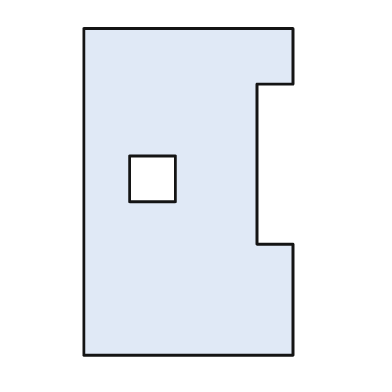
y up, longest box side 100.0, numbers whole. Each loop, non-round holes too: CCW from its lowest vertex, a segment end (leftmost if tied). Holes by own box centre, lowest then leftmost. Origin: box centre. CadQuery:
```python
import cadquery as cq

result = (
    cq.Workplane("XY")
    .moveTo(-32.0, -50.0)
    .lineTo(32.0, -50.0)
    .lineTo(32.0, -16.0)
    .lineTo(21.0, -16.0)
    .lineTo(21.0, 33.0)
    .lineTo(32.0, 33.0)
    .lineTo(32.0, 50.0)
    .lineTo(-32.0, 50.0)
    .close()
    .moveTo(-18.0, -3.0)
    .lineTo(-4.0, -3.0)
    .lineTo(-4.0, 11.0)
    .lineTo(-18.0, 11.0)
    .close()
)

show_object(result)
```